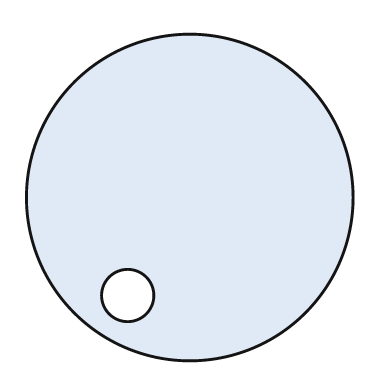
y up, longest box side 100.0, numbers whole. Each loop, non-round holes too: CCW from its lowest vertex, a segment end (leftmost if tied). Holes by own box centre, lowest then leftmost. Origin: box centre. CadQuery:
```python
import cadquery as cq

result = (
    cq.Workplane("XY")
    .moveTo(0.0, 0.0)
    .circle(50.0)
    .moveTo(-19.0, -30.0)
    .circle(8.0)
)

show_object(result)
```